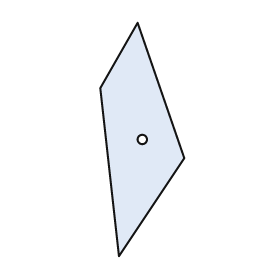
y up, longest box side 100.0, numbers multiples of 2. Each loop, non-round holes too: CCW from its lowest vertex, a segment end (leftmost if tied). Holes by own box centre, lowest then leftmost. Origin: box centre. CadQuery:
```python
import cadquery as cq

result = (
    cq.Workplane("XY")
    .moveTo(-10.0, -50.0)
    .lineTo(18.0, -8.0)
    .lineTo(-2.0, 50.0)
    .lineTo(-18.0, 22.0)
    .close()
    .moveTo(0.0, 0.0)
    .circle(2.0)
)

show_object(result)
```